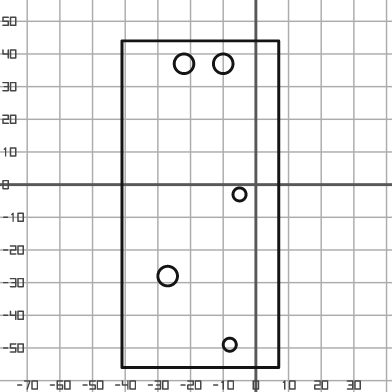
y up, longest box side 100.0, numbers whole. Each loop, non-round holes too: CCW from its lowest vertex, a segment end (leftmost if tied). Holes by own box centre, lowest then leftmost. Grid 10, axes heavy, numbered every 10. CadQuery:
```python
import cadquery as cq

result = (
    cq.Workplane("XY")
    .moveTo(-41.0, -56.0)
    .lineTo(7.0, -56.0)
    .lineTo(7.0, 44.0)
    .lineTo(-41.0, 44.0)
    .close()
    .moveTo(-8.0, -49.0)
    .circle(2.0)
    .moveTo(-27.0, -28.0)
    .circle(3.0)
    .moveTo(-5.0, -3.0)
    .circle(2.0)
    .moveTo(-22.0, 37.0)
    .circle(3.0)
    .moveTo(-10.0, 37.0)
    .circle(3.0)
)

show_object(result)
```